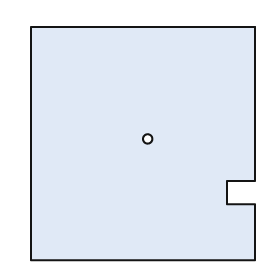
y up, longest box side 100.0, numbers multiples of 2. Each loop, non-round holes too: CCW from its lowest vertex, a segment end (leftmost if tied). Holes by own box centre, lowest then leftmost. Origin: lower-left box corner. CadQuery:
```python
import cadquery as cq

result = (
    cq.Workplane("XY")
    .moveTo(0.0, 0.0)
    .lineTo(96.0, 0.0)
    .lineTo(96.0, 24.0)
    .lineTo(84.0, 24.0)
    .lineTo(84.0, 34.0)
    .lineTo(96.0, 34.0)
    .lineTo(96.0, 100.0)
    .lineTo(0.0, 100.0)
    .close()
    .moveTo(50.0, 52.0)
    .circle(2.0)
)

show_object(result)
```